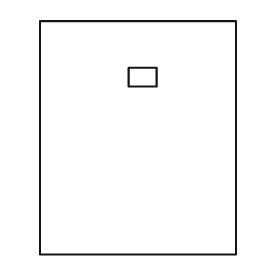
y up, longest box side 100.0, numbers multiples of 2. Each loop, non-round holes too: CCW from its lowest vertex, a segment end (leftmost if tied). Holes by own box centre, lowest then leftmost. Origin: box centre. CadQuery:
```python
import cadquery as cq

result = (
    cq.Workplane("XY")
    .moveTo(-42.0, -50.0)
    .lineTo(42.0, -50.0)
    .lineTo(42.0, 50.0)
    .lineTo(-42.0, 50.0)
    .close()
    .moveTo(-4.0, 22.0)
    .lineTo(8.0, 22.0)
    .lineTo(8.0, 30.0)
    .lineTo(-4.0, 30.0)
    .close()
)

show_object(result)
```